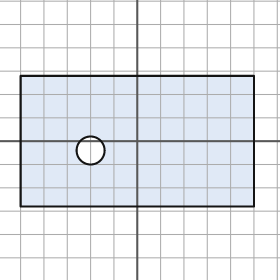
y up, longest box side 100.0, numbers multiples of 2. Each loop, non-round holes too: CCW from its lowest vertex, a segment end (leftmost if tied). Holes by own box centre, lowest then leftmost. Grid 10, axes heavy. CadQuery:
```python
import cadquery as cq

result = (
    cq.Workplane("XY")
    .moveTo(-50.0, -28.0)
    .lineTo(50.0, -28.0)
    .lineTo(50.0, 28.0)
    .lineTo(-50.0, 28.0)
    .close()
    .moveTo(-20.0, -4.0)
    .circle(6.0)
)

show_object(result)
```